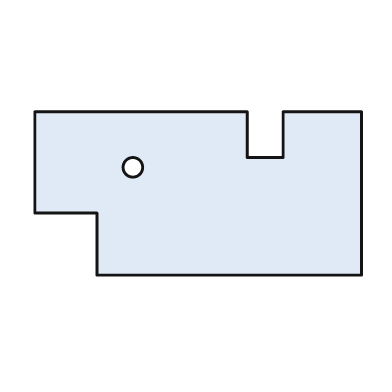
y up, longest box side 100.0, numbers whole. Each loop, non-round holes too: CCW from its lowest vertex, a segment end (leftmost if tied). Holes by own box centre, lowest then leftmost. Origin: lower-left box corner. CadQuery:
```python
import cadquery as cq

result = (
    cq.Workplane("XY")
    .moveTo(19.0, 0.0)
    .lineTo(100.0, 0.0)
    .lineTo(100.0, 50.0)
    .lineTo(76.0, 50.0)
    .lineTo(76.0, 36.0)
    .lineTo(65.0, 36.0)
    .lineTo(65.0, 50.0)
    .lineTo(0.0, 50.0)
    .lineTo(0.0, 19.0)
    .lineTo(19.0, 19.0)
    .close()
    .moveTo(30.0, 33.0)
    .circle(3.0)
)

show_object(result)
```